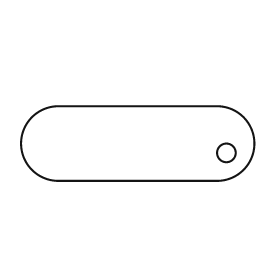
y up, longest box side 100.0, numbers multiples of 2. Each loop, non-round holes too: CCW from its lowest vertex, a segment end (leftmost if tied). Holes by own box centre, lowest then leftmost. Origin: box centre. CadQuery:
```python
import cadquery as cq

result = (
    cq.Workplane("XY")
    .moveTo(-34.0, -16.0)
    .lineTo(34.0, -16.0)
    .threePointArc((50.0, 0.0), (34.0, 16.0))
    .lineTo(-34.0, 16.0)
    .threePointArc((-50.0, 0.0), (-34.0, -16.0))
    .close()
    .moveTo(38.0, -4.0)
    .circle(4.0)
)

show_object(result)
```